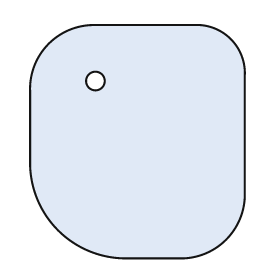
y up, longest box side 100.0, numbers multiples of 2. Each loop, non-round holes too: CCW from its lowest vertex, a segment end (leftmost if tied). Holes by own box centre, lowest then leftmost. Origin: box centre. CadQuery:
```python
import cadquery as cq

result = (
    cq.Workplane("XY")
    .moveTo(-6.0, -50.0)
    .lineTo(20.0, -50.0)
    .threePointArc((38.0, -42.0), (46.0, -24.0))
    .lineTo(46.0, 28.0)
    .threePointArc((40.0, 44.0), (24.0, 50.0))
    .lineTo(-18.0, 50.0)
    .threePointArc((-38.0, 42.0), (-46.0, 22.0))
    .lineTo(-46.0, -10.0)
    .threePointArc((-34.0, -38.0), (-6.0, -50.0))
    .close()
    .moveTo(-18.0, 26.0)
    .circle(4.0)
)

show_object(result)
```